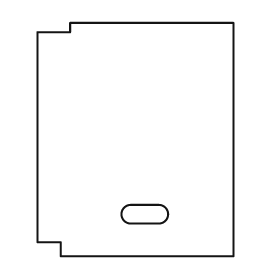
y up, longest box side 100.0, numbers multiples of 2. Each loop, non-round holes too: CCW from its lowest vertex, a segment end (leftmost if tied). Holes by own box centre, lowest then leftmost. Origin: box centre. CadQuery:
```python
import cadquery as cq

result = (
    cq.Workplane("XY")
    .moveTo(-32.0, -50.0)
    .lineTo(42.0, -50.0)
    .lineTo(42.0, 50.0)
    .lineTo(-28.0, 50.0)
    .lineTo(-28.0, 46.0)
    .lineTo(-42.0, 46.0)
    .lineTo(-42.0, -44.0)
    .lineTo(-32.0, -44.0)
    .close()
    .moveTo(-2.0, -36.0)
    .lineTo(10.0, -36.0)
    .threePointArc((14.0, -32.0), (10.0, -28.0))
    .lineTo(-2.0, -28.0)
    .threePointArc((-6.0, -32.0), (-2.0, -36.0))
    .close()
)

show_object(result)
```